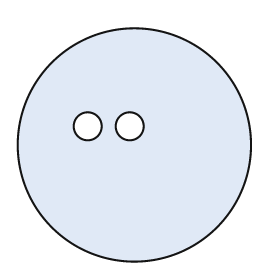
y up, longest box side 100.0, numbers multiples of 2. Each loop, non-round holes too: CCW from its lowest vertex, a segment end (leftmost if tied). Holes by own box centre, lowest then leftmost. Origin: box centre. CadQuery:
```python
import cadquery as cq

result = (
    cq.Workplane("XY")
    .moveTo(0.0, 0.0)
    .circle(50.0)
    .moveTo(-20.0, 8.0)
    .circle(6.0)
    .moveTo(-2.0, 8.0)
    .circle(6.0)
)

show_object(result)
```